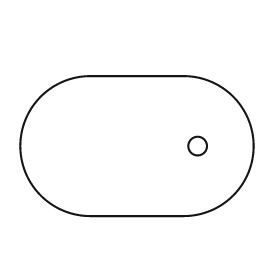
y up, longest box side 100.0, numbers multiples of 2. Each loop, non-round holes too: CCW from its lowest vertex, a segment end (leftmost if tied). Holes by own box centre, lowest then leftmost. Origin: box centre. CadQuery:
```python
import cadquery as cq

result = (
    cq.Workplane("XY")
    .moveTo(-20.0, -30.0)
    .lineTo(20.0, -30.0)
    .threePointArc((50.0, 0.0), (20.0, 30.0))
    .lineTo(-20.0, 30.0)
    .threePointArc((-50.0, 0.0), (-20.0, -30.0))
    .close()
    .moveTo(26.0, 0.0)
    .circle(4.0)
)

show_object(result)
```